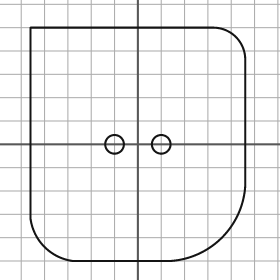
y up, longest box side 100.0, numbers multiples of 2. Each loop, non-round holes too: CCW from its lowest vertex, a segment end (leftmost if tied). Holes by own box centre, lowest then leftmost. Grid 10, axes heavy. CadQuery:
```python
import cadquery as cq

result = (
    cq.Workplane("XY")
    .moveTo(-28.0, -50.0)
    .lineTo(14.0, -50.0)
    .threePointArc((36.0, -40.0), (46.0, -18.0))
    .lineTo(46.0, 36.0)
    .threePointArc((42.0, 46.0), (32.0, 50.0))
    .lineTo(-46.0, 50.0)
    .lineTo(-46.0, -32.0)
    .threePointArc((-40.0, -44.0), (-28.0, -50.0))
    .close()
    .moveTo(-10.0, 0.0)
    .circle(4.0)
    .moveTo(10.0, 0.0)
    .circle(4.0)
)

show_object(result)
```